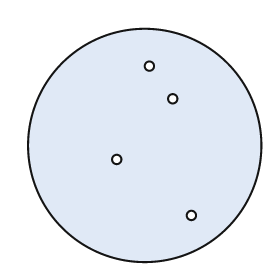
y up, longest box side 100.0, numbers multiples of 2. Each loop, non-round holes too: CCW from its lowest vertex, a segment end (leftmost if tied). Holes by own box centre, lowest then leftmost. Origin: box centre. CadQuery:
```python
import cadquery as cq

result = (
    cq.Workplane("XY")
    .moveTo(0.0, 0.0)
    .circle(50.0)
    .moveTo(20.0, -30.0)
    .circle(2.0)
    .moveTo(-12.0, -6.0)
    .circle(2.0)
    .moveTo(12.0, 20.0)
    .circle(2.0)
    .moveTo(2.0, 34.0)
    .circle(2.0)
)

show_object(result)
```